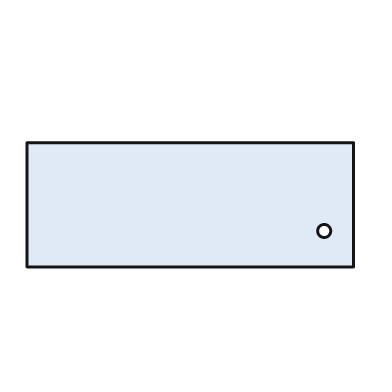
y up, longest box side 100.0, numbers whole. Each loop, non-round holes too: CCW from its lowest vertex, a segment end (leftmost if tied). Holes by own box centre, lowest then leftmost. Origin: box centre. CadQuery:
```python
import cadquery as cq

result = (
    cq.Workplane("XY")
    .moveTo(-50.0, -19.0)
    .lineTo(50.0, -19.0)
    .lineTo(50.0, 19.0)
    .lineTo(-50.0, 19.0)
    .close()
    .moveTo(41.0, -8.0)
    .circle(2.0)
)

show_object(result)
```